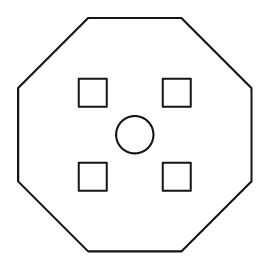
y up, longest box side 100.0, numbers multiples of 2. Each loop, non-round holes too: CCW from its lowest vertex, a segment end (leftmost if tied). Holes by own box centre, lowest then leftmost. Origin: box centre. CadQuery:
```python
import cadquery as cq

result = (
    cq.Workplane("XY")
    .moveTo(-20.0, -50.0)
    .lineTo(20.0, -50.0)
    .lineTo(50.0, -20.0)
    .lineTo(50.0, 20.0)
    .lineTo(20.0, 50.0)
    .lineTo(-20.0, 50.0)
    .lineTo(-50.0, 20.0)
    .lineTo(-50.0, -20.0)
    .close()
    .moveTo(-24.0, -24.0)
    .lineTo(-12.0, -24.0)
    .lineTo(-12.0, -12.0)
    .lineTo(-24.0, -12.0)
    .close()
    .moveTo(12.0, -24.0)
    .lineTo(24.0, -24.0)
    .lineTo(24.0, -12.0)
    .lineTo(12.0, -12.0)
    .close()
    .moveTo(0.0, 0.0)
    .circle(8.0)
    .moveTo(-24.0, 12.0)
    .lineTo(-12.0, 12.0)
    .lineTo(-12.0, 24.0)
    .lineTo(-24.0, 24.0)
    .close()
    .moveTo(12.0, 12.0)
    .lineTo(24.0, 12.0)
    .lineTo(24.0, 24.0)
    .lineTo(12.0, 24.0)
    .close()
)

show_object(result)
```